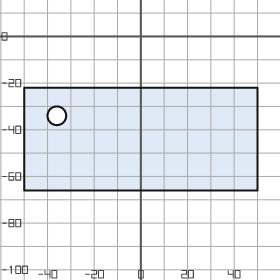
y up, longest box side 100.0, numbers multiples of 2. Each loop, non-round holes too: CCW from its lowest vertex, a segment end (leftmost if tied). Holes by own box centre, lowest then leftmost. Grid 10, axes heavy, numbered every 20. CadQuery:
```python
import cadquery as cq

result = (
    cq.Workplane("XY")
    .moveTo(-50.0, -66.0)
    .lineTo(50.0, -66.0)
    .lineTo(50.0, -22.0)
    .lineTo(-50.0, -22.0)
    .close()
    .moveTo(-36.0, -34.0)
    .circle(4.0)
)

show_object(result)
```